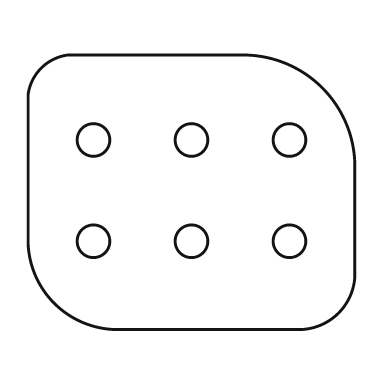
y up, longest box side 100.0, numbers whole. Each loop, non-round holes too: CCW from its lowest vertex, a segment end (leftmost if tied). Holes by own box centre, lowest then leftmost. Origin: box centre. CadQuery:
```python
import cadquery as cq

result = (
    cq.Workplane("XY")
    .moveTo(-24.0, -42.0)
    .lineTo(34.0, -42.0)
    .threePointArc((45.0, -37.0), (50.0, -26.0))
    .lineTo(50.0, 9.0)
    .threePointArc((40.0, 32.0), (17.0, 42.0))
    .lineTo(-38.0, 42.0)
    .threePointArc((-46.0, 38.0), (-50.0, 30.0))
    .lineTo(-50.0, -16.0)
    .threePointArc((-42.0, -34.0), (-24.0, -42.0))
    .close()
    .moveTo(-30.0, -15.0)
    .circle(5.0)
    .moveTo(0.0, -15.0)
    .circle(5.0)
    .moveTo(30.0, -15.0)
    .circle(5.0)
    .moveTo(-30.0, 16.0)
    .circle(5.0)
    .moveTo(0.0, 16.0)
    .circle(5.0)
    .moveTo(30.0, 16.0)
    .circle(5.0)
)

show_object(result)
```